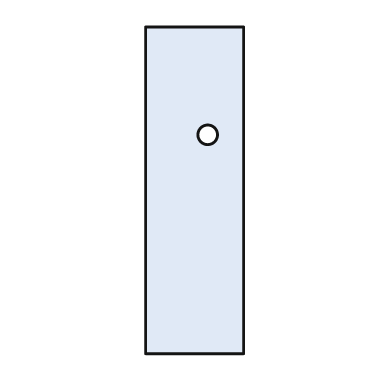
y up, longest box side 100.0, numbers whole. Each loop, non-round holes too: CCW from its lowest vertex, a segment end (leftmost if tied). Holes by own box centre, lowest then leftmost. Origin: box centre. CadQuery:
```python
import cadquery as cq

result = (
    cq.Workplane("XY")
    .moveTo(-15.0, -50.0)
    .lineTo(15.0, -50.0)
    .lineTo(15.0, 50.0)
    .lineTo(-15.0, 50.0)
    .close()
    .moveTo(4.0, 17.0)
    .circle(3.0)
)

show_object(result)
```